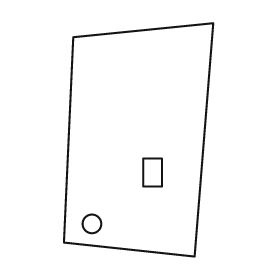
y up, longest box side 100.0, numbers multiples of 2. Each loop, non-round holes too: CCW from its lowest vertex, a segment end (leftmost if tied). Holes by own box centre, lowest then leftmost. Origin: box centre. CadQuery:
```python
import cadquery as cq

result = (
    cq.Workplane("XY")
    .moveTo(24.0, -50.0)
    .lineTo(32.0, 50.0)
    .lineTo(-28.0, 44.0)
    .lineTo(-32.0, -44.0)
    .close()
    .moveTo(-20.0, -36.0)
    .circle(4.0)
    .moveTo(2.0, -20.0)
    .lineTo(10.0, -20.0)
    .lineTo(10.0, -8.0)
    .lineTo(2.0, -8.0)
    .close()
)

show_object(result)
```